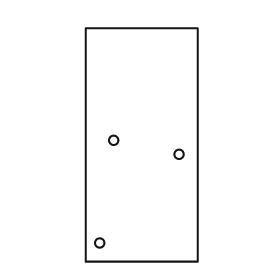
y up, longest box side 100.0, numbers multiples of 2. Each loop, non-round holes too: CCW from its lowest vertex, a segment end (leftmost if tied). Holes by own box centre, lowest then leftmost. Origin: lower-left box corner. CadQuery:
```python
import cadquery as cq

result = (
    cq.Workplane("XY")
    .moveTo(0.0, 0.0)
    .lineTo(48.0, 0.0)
    .lineTo(48.0, 100.0)
    .lineTo(0.0, 100.0)
    .close()
    .moveTo(6.0, 8.0)
    .circle(2.0)
    .moveTo(40.0, 46.0)
    .circle(2.0)
    .moveTo(12.0, 52.0)
    .circle(2.0)
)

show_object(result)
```